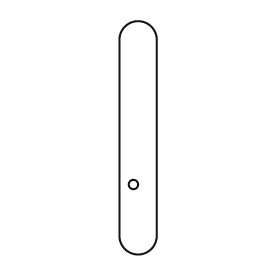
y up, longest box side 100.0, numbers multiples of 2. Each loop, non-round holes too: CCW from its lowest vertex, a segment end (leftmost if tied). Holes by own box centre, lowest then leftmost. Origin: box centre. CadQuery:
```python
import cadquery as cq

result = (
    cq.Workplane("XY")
    .moveTo(-8.0, -42.0)
    .threePointArc((0.0, -50.0), (8.0, -42.0))
    .lineTo(8.0, 42.0)
    .threePointArc((0.0, 50.0), (-8.0, 42.0))
    .close()
    .moveTo(-2.0, -20.0)
    .circle(2.0)
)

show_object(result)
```